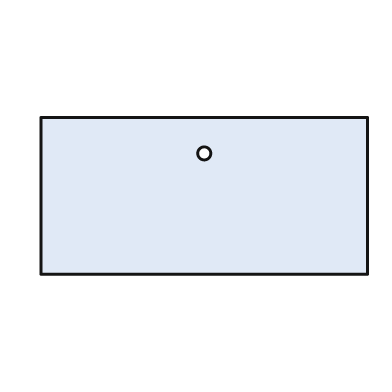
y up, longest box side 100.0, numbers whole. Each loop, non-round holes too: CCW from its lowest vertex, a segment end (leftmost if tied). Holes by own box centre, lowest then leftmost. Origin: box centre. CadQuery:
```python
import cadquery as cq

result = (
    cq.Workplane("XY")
    .moveTo(-50.0, -24.0)
    .lineTo(50.0, -24.0)
    .lineTo(50.0, 24.0)
    .lineTo(-50.0, 24.0)
    .close()
    .moveTo(0.0, 13.0)
    .circle(2.0)
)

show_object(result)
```